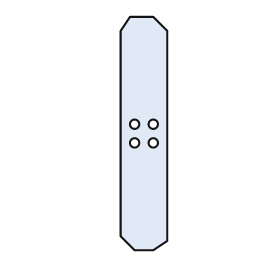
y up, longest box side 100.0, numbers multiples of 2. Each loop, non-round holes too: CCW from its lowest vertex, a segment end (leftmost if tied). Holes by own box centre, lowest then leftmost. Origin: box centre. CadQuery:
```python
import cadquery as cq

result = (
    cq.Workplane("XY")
    .moveTo(-4.0, -50.0)
    .lineTo(4.0, -50.0)
    .lineTo(10.0, -46.0)
    .lineTo(10.0, 44.0)
    .lineTo(4.0, 50.0)
    .lineTo(-6.0, 50.0)
    .lineTo(-10.0, 44.0)
    .lineTo(-10.0, -44.0)
    .close()
    .moveTo(-4.0, -4.0)
    .circle(2.0)
    .moveTo(4.0, -4.0)
    .circle(2.0)
    .moveTo(-4.0, 4.0)
    .circle(2.0)
    .moveTo(4.0, 4.0)
    .circle(2.0)
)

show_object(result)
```